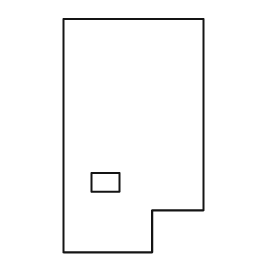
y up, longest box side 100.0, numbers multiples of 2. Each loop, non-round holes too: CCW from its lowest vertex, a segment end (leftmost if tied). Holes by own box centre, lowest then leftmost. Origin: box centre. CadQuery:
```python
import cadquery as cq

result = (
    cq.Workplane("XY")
    .moveTo(-30.0, -50.0)
    .lineTo(8.0, -50.0)
    .lineTo(8.0, -32.0)
    .lineTo(30.0, -32.0)
    .lineTo(30.0, 50.0)
    .lineTo(-30.0, 50.0)
    .close()
    .moveTo(-18.0, -24.0)
    .lineTo(-6.0, -24.0)
    .lineTo(-6.0, -16.0)
    .lineTo(-18.0, -16.0)
    .close()
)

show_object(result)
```